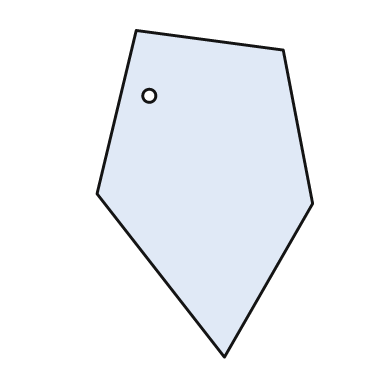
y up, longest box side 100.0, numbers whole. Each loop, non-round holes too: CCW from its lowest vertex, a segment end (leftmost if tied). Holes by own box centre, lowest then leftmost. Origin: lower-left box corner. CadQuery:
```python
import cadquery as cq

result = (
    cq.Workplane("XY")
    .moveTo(39.0, 0.0)
    .lineTo(66.0, 47.0)
    .lineTo(57.0, 94.0)
    .lineTo(12.0, 100.0)
    .lineTo(0.0, 50.0)
    .close()
    .moveTo(16.0, 80.0)
    .circle(2.0)
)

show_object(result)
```